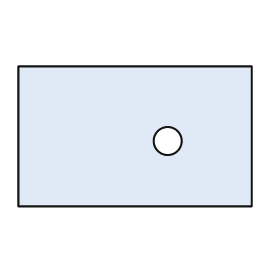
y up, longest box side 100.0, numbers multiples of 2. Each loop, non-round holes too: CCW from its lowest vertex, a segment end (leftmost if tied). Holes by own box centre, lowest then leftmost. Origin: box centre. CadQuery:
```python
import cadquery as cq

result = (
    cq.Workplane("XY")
    .moveTo(-50.0, -30.0)
    .lineTo(50.0, -30.0)
    .lineTo(50.0, 30.0)
    .lineTo(-50.0, 30.0)
    .close()
    .moveTo(14.0, -2.0)
    .circle(6.0)
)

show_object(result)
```